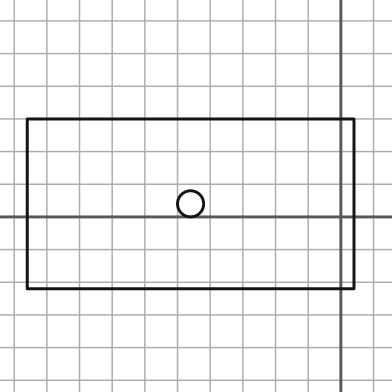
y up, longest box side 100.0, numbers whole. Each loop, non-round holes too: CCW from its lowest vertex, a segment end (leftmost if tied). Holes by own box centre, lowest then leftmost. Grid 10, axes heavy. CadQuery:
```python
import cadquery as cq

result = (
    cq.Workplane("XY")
    .moveTo(-96.0, -22.0)
    .lineTo(4.0, -22.0)
    .lineTo(4.0, 30.0)
    .lineTo(-96.0, 30.0)
    .close()
    .moveTo(-46.0, 4.0)
    .circle(4.0)
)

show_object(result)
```